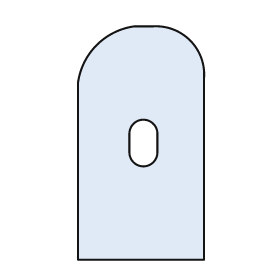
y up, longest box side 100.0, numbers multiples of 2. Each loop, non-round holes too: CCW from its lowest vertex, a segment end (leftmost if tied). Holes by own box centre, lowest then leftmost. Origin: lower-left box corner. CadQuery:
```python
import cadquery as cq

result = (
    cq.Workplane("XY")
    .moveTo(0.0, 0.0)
    .lineTo(54.0, 0.0)
    .lineTo(54.0, 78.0)
    .threePointArc((48.0, 94.0), (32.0, 100.0))
    .lineTo(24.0, 100.0)
    .threePointArc((8.0, 92.0), (0.0, 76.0))
    .close()
    .moveTo(22.0, 46.0)
    .threePointArc((28.0, 40.0), (34.0, 46.0))
    .lineTo(34.0, 54.0)
    .threePointArc((28.0, 60.0), (22.0, 54.0))
    .close()
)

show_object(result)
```